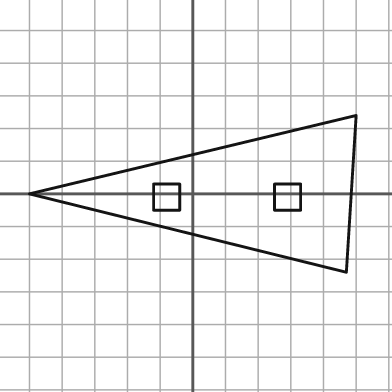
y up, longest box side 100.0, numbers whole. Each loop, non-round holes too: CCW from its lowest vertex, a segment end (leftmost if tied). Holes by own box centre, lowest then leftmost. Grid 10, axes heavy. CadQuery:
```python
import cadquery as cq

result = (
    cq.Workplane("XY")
    .moveTo(47.0, -24.0)
    .lineTo(50.0, 24.0)
    .lineTo(-50.0, 0.0)
    .close()
    .moveTo(-12.0, -5.0)
    .lineTo(-4.0, -5.0)
    .lineTo(-4.0, 3.0)
    .lineTo(-12.0, 3.0)
    .close()
    .moveTo(25.0, -5.0)
    .lineTo(33.0, -5.0)
    .lineTo(33.0, 3.0)
    .lineTo(25.0, 3.0)
    .close()
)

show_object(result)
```